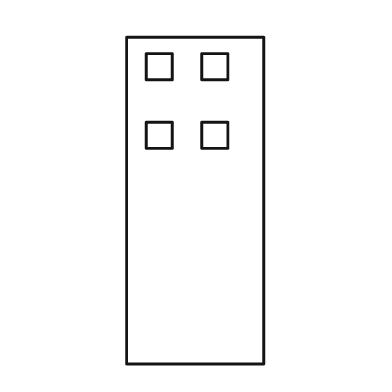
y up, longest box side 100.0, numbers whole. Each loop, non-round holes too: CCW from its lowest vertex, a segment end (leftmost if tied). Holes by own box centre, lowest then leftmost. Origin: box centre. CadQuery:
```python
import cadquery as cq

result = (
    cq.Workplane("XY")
    .moveTo(-21.0, -50.0)
    .lineTo(21.0, -50.0)
    .lineTo(21.0, 50.0)
    .lineTo(-21.0, 50.0)
    .close()
    .moveTo(-15.0, 16.0)
    .lineTo(-7.0, 16.0)
    .lineTo(-7.0, 24.0)
    .lineTo(-15.0, 24.0)
    .close()
    .moveTo(2.0, 16.0)
    .lineTo(10.0, 16.0)
    .lineTo(10.0, 24.0)
    .lineTo(2.0, 24.0)
    .close()
    .moveTo(-15.0, 37.0)
    .lineTo(-7.0, 37.0)
    .lineTo(-7.0, 45.0)
    .lineTo(-15.0, 45.0)
    .close()
    .moveTo(2.0, 37.0)
    .lineTo(10.0, 37.0)
    .lineTo(10.0, 45.0)
    .lineTo(2.0, 45.0)
    .close()
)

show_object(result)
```